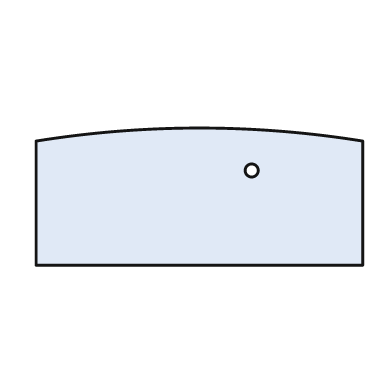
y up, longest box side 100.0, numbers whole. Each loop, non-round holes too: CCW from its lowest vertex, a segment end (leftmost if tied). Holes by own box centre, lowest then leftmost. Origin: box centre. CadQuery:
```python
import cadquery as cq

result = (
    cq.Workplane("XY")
    .moveTo(-50.0, -21.0)
    .lineTo(50.0, -21.0)
    .lineTo(50.0, 17.0)
    .threePointArc((0.0, 21.0), (-50.0, 17.0))
    .close()
    .moveTo(16.0, 8.0)
    .circle(2.0)
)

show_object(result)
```